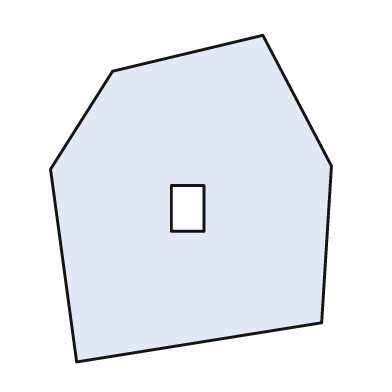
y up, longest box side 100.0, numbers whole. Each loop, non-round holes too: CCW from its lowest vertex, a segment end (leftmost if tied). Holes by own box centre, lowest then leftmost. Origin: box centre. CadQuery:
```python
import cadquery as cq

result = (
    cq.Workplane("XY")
    .moveTo(-35.0, -50.0)
    .lineTo(40.0, -38.0)
    .lineTo(43.0, 10.0)
    .lineTo(22.0, 50.0)
    .lineTo(-24.0, 39.0)
    .lineTo(-43.0, 9.0)
    .close()
    .moveTo(-6.0, -10.0)
    .lineTo(4.0, -10.0)
    .lineTo(4.0, 4.0)
    .lineTo(-6.0, 4.0)
    .close()
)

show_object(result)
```